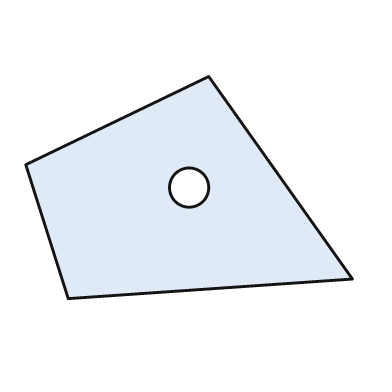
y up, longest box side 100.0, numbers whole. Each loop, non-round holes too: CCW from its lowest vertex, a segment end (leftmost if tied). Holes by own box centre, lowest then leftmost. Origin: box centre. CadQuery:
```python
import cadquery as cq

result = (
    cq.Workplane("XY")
    .moveTo(-37.0, -34.0)
    .lineTo(50.0, -28.0)
    .lineTo(6.0, 34.0)
    .lineTo(-50.0, 7.0)
    .close()
    .moveTo(0.0, 0.0)
    .circle(6.0)
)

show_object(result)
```